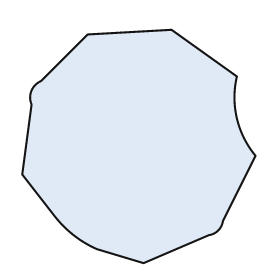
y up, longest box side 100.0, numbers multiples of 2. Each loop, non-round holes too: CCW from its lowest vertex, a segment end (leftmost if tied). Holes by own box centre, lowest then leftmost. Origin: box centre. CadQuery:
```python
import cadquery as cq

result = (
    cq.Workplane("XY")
    .moveTo(2.0, -50.0)
    .lineTo(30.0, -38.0)
    .threePointArc((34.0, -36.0), (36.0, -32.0))
    .lineTo(50.0, -4.0)
    .threePointArc((42.0, 12.0), (42.0, 30.0))
    .lineTo(14.0, 50.0)
    .lineTo(-22.0, 48.0)
    .lineTo(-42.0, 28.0)
    .threePointArc((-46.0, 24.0), (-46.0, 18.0))
    .lineTo(-50.0, -12.0)
    .lineTo(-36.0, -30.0)
    .threePointArc((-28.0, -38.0), (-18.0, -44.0))
    .close()
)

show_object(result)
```